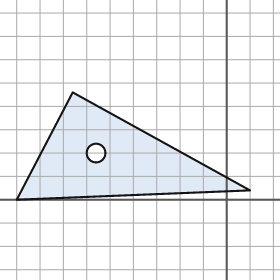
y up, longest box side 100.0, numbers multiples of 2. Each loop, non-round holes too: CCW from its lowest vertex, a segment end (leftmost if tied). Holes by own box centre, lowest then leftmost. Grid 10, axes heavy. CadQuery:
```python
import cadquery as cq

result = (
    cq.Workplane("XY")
    .moveTo(-90.0, 0.0)
    .lineTo(10.0, 4.0)
    .lineTo(-66.0, 46.0)
    .close()
    .moveTo(-56.0, 20.0)
    .circle(4.0)
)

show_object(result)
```